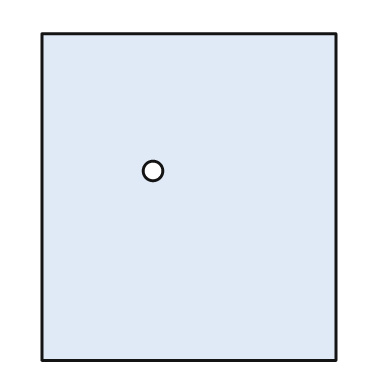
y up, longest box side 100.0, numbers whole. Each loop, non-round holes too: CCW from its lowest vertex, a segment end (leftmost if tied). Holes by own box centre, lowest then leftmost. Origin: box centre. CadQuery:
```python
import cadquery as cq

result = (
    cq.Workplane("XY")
    .moveTo(-45.0, -50.0)
    .lineTo(45.0, -50.0)
    .lineTo(45.0, 50.0)
    .lineTo(-45.0, 50.0)
    .close()
    .moveTo(-11.0, 8.0)
    .circle(3.0)
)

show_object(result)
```